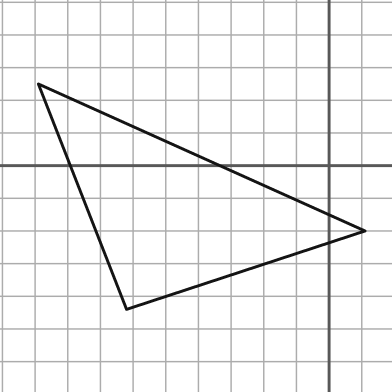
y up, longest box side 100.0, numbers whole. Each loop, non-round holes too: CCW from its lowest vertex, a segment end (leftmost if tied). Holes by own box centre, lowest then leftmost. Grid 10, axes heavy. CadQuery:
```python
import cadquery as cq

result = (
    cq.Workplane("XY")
    .moveTo(-62.0, -44.0)
    .lineTo(11.0, -20.0)
    .lineTo(-89.0, 25.0)
    .close()
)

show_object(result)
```